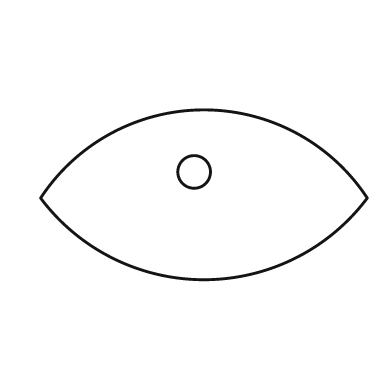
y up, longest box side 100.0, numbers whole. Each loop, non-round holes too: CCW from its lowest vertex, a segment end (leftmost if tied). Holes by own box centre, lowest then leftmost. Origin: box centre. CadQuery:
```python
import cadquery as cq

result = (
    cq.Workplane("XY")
    .moveTo(-50.0, -1.0)
    .threePointArc((0.0, -26.0), (50.0, -1.0))
    .threePointArc((0.0, 26.0), (-50.0, -1.0))
    .close()
    .moveTo(-3.0, 7.0)
    .circle(5.0)
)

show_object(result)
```